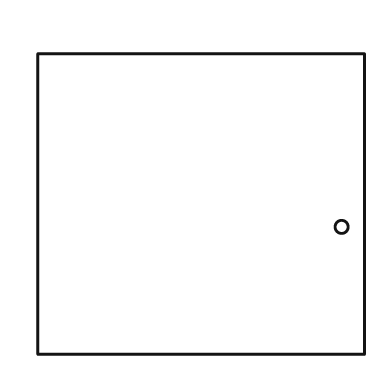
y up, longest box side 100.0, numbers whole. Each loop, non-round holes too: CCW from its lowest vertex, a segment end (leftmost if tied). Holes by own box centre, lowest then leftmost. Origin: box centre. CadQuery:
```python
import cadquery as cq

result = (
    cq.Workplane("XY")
    .moveTo(-50.0, -46.0)
    .lineTo(50.0, -46.0)
    .lineTo(50.0, 46.0)
    .lineTo(-50.0, 46.0)
    .close()
    .moveTo(43.0, -7.0)
    .circle(2.0)
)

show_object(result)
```